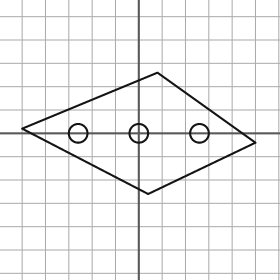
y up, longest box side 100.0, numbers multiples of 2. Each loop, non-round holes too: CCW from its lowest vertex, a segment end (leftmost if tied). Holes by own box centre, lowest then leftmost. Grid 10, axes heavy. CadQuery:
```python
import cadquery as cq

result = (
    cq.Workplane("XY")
    .moveTo(4.0, -26.0)
    .lineTo(50.0, -4.0)
    .lineTo(8.0, 26.0)
    .lineTo(-50.0, 2.0)
    .close()
    .moveTo(-26.0, 0.0)
    .circle(4.0)
    .moveTo(0.0, 0.0)
    .circle(4.0)
    .moveTo(26.0, 0.0)
    .circle(4.0)
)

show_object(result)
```